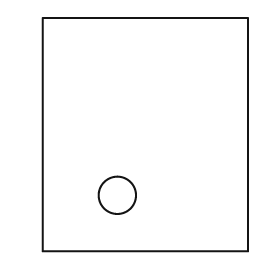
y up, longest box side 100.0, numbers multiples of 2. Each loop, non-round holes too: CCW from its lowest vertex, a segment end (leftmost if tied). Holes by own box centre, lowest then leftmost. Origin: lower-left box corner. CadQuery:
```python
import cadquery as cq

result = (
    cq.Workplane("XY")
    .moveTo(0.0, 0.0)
    .lineTo(88.0, 0.0)
    .lineTo(88.0, 100.0)
    .lineTo(0.0, 100.0)
    .close()
    .moveTo(32.0, 24.0)
    .circle(8.0)
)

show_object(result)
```